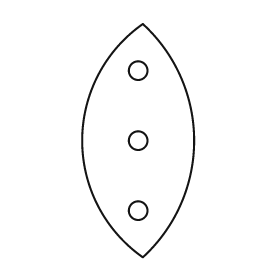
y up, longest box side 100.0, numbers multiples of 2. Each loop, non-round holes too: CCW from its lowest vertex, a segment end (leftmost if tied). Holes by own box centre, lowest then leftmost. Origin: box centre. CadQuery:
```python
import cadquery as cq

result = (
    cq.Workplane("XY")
    .moveTo(2.0, -50.0)
    .threePointArc((24.0, 0.0), (2.0, 50.0))
    .threePointArc((-24.0, 0.0), (2.0, -50.0))
    .close()
    .moveTo(0.0, -30.0)
    .circle(4.0)
    .moveTo(0.0, 0.0)
    .circle(4.0)
    .moveTo(0.0, 30.0)
    .circle(4.0)
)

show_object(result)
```